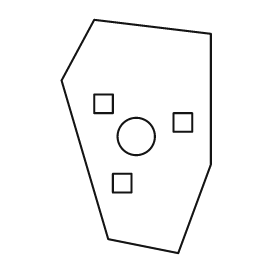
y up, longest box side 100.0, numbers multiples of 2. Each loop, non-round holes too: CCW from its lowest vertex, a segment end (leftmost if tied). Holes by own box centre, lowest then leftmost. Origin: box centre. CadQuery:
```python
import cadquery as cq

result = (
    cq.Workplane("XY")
    .moveTo(18.0, -50.0)
    .lineTo(32.0, -12.0)
    .lineTo(32.0, 44.0)
    .lineTo(-18.0, 50.0)
    .lineTo(-32.0, 24.0)
    .lineTo(-12.0, -44.0)
    .close()
    .moveTo(-10.0, -24.0)
    .lineTo(-2.0, -24.0)
    .lineTo(-2.0, -16.0)
    .lineTo(-10.0, -16.0)
    .close()
    .moveTo(0.0, 0.0)
    .circle(8.0)
    .moveTo(16.0, 2.0)
    .lineTo(24.0, 2.0)
    .lineTo(24.0, 10.0)
    .lineTo(16.0, 10.0)
    .close()
    .moveTo(-18.0, 10.0)
    .lineTo(-10.0, 10.0)
    .lineTo(-10.0, 18.0)
    .lineTo(-18.0, 18.0)
    .close()
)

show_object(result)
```